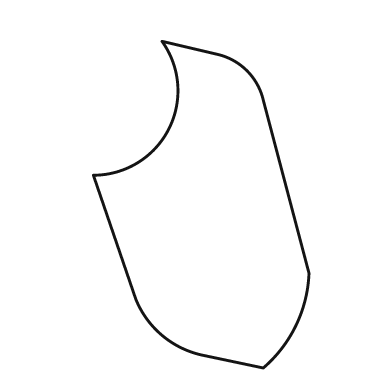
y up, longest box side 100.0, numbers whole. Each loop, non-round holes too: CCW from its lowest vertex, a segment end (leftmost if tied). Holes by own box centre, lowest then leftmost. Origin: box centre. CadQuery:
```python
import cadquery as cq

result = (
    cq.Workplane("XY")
    .moveTo(19.0, -50.0)
    .threePointArc((29.0, -37.0), (33.0, -21.0))
    .lineTo(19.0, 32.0)
    .threePointArc((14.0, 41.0), (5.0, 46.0))
    .lineTo(-12.0, 50.0)
    .threePointArc((-10.0, 23.0), (-33.0, 9.0))
    .lineTo(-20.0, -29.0)
    .threePointArc((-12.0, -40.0), (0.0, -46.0))
    .close()
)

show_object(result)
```